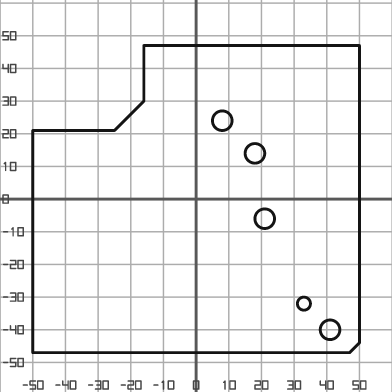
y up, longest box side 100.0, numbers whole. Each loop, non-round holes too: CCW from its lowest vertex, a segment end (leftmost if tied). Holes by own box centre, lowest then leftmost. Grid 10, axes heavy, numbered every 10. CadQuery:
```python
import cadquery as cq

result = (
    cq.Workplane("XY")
    .moveTo(-50.0, -47.0)
    .lineTo(47.0, -47.0)
    .lineTo(50.0, -44.0)
    .lineTo(50.0, 47.0)
    .lineTo(-16.0, 47.0)
    .lineTo(-16.0, 30.0)
    .lineTo(-25.0, 21.0)
    .lineTo(-50.0, 21.0)
    .close()
    .moveTo(41.0, -40.0)
    .circle(3.0)
    .moveTo(33.0, -32.0)
    .circle(2.0)
    .moveTo(21.0, -6.0)
    .circle(3.0)
    .moveTo(18.0, 14.0)
    .circle(3.0)
    .moveTo(8.0, 24.0)
    .circle(3.0)
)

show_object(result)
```